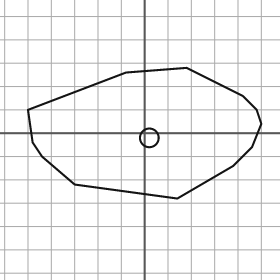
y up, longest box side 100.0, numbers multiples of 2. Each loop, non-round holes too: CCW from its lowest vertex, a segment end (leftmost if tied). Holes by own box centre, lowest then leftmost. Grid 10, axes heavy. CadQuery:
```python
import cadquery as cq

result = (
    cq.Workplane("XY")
    .moveTo(14.0, -28.0)
    .lineTo(38.0, -14.0)
    .lineTo(46.0, -6.0)
    .lineTo(50.0, 4.0)
    .lineTo(48.0, 10.0)
    .lineTo(42.0, 16.0)
    .lineTo(18.0, 28.0)
    .lineTo(-8.0, 26.0)
    .lineTo(-50.0, 10.0)
    .lineTo(-48.0, -4.0)
    .lineTo(-44.0, -10.0)
    .lineTo(-30.0, -22.0)
    .close()
    .moveTo(2.0, -2.0)
    .circle(4.0)
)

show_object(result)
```